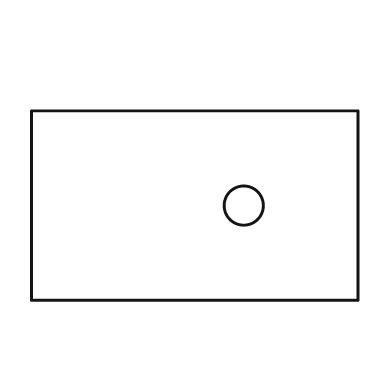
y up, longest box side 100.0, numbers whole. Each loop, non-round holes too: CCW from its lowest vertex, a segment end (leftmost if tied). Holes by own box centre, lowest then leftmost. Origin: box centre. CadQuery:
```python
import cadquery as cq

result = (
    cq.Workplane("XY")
    .moveTo(-50.0, -29.0)
    .lineTo(50.0, -29.0)
    .lineTo(50.0, 29.0)
    .lineTo(-50.0, 29.0)
    .close()
    .moveTo(15.0, 0.0)
    .circle(6.0)
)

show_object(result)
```